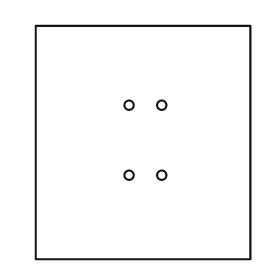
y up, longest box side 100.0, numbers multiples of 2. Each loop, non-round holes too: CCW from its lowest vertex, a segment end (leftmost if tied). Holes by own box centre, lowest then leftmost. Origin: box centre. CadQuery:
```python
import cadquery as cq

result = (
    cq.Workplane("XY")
    .moveTo(-46.0, -50.0)
    .lineTo(46.0, -50.0)
    .lineTo(46.0, 50.0)
    .lineTo(-46.0, 50.0)
    .close()
    .moveTo(-6.0, -14.0)
    .circle(2.0)
    .moveTo(8.0, -14.0)
    .circle(2.0)
    .moveTo(-6.0, 16.0)
    .circle(2.0)
    .moveTo(8.0, 16.0)
    .circle(2.0)
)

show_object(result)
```